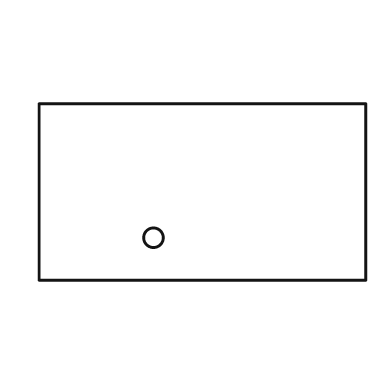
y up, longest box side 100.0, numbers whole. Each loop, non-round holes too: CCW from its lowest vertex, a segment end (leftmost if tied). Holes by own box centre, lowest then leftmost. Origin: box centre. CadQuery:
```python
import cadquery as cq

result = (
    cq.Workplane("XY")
    .moveTo(-50.0, -27.0)
    .lineTo(50.0, -27.0)
    .lineTo(50.0, 27.0)
    .lineTo(-50.0, 27.0)
    .close()
    .moveTo(-15.0, -14.0)
    .circle(3.0)
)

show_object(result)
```